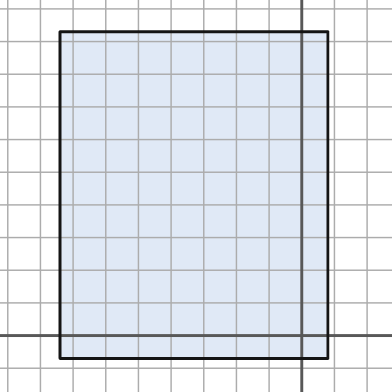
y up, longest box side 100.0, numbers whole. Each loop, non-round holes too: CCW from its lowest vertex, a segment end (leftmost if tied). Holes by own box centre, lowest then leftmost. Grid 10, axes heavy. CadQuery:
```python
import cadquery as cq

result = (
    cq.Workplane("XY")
    .moveTo(-74.0, -7.0)
    .lineTo(8.0, -7.0)
    .lineTo(8.0, 93.0)
    .lineTo(-74.0, 93.0)
    .close()
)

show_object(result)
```